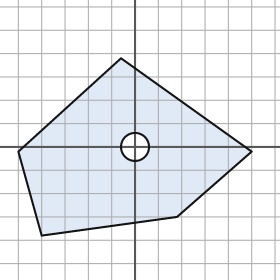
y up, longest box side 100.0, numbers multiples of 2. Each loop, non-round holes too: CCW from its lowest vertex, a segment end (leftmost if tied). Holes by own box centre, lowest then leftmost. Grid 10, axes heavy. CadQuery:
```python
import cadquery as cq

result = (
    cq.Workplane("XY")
    .moveTo(-40.0, -38.0)
    .lineTo(18.0, -30.0)
    .lineTo(50.0, -2.0)
    .lineTo(-6.0, 38.0)
    .lineTo(-50.0, -2.0)
    .close()
    .moveTo(0.0, 0.0)
    .circle(6.0)
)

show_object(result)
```